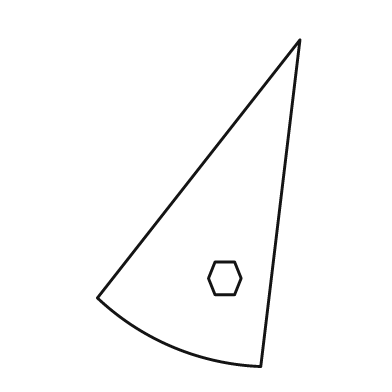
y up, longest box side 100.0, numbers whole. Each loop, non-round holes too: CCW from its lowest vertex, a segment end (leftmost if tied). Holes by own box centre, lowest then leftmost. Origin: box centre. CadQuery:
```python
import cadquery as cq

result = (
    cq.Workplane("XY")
    .moveTo(19.0, -50.0)
    .lineTo(31.0, 50.0)
    .lineTo(-31.0, -29.0)
    .threePointArc((-8.0, -44.0), (19.0, -50.0))
    .close()
    .moveTo(5.0, -28.0)
    .lineTo(11.0, -28.0)
    .lineTo(13.0, -23.0)
    .lineTo(11.0, -18.0)
    .lineTo(5.0, -18.0)
    .lineTo(3.0, -23.0)
    .close()
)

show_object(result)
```